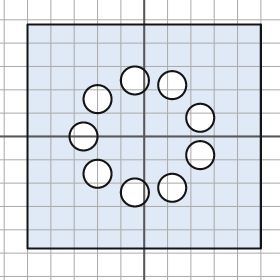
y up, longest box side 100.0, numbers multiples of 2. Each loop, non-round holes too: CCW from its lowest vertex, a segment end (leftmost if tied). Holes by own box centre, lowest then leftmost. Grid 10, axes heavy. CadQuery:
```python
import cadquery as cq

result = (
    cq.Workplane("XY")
    .moveTo(-50.0, -48.0)
    .lineTo(50.0, -48.0)
    .lineTo(50.0, 48.0)
    .lineTo(-50.0, 48.0)
    .close()
    .moveTo(-4.0, -24.0)
    .circle(6.0)
    .moveTo(12.0, -22.0)
    .circle(6.0)
    .moveTo(-20.0, -16.0)
    .circle(6.0)
    .moveTo(24.0, -8.0)
    .circle(6.0)
    .moveTo(-26.0, 0.0)
    .circle(6.0)
    .moveTo(24.0, 8.0)
    .circle(6.0)
    .moveTo(-20.0, 16.0)
    .circle(6.0)
    .moveTo(12.0, 22.0)
    .circle(6.0)
    .moveTo(-4.0, 24.0)
    .circle(6.0)
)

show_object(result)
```